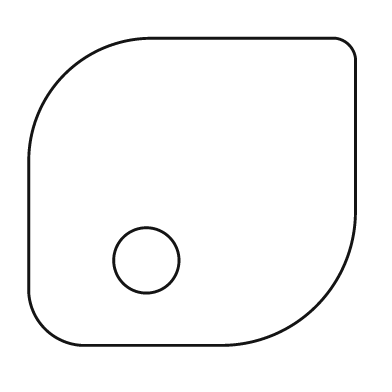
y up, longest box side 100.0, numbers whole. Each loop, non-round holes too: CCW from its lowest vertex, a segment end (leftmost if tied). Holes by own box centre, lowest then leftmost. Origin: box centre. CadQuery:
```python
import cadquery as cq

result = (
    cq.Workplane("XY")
    .moveTo(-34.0, -47.0)
    .lineTo(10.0, -47.0)
    .threePointArc((38.0, -35.0), (50.0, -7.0))
    .lineTo(50.0, 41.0)
    .threePointArc((48.0, 45.0), (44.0, 47.0))
    .lineTo(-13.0, 47.0)
    .threePointArc((-39.0, 36.0), (-50.0, 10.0))
    .lineTo(-50.0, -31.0)
    .threePointArc((-45.0, -42.0), (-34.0, -47.0))
    .close()
    .moveTo(-14.0, -21.0)
    .circle(10.0)
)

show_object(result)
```